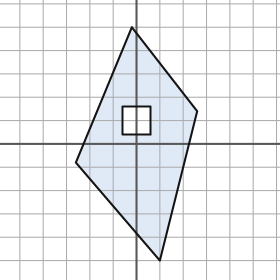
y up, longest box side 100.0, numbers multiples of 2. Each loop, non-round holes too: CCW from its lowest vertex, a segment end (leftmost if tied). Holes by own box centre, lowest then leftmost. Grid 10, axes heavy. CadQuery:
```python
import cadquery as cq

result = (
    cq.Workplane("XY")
    .moveTo(10.0, -50.0)
    .lineTo(26.0, 14.0)
    .lineTo(-2.0, 50.0)
    .lineTo(-26.0, -8.0)
    .close()
    .moveTo(-6.0, 4.0)
    .lineTo(6.0, 4.0)
    .lineTo(6.0, 16.0)
    .lineTo(-6.0, 16.0)
    .close()
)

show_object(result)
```